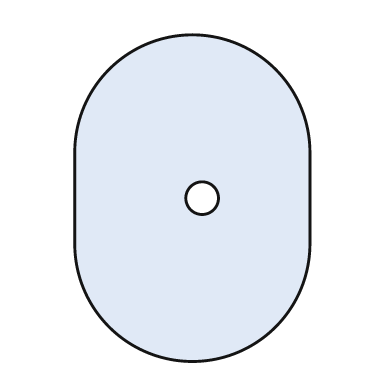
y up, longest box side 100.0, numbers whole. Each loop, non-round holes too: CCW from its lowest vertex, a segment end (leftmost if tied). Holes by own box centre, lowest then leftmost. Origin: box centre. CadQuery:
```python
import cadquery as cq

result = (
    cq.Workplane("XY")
    .moveTo(-36.0, -14.0)
    .threePointArc((0.0, -50.0), (36.0, -14.0))
    .lineTo(36.0, 14.0)
    .threePointArc((0.0, 50.0), (-36.0, 14.0))
    .close()
    .moveTo(3.0, 0.0)
    .circle(5.0)
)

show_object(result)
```